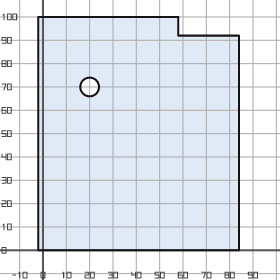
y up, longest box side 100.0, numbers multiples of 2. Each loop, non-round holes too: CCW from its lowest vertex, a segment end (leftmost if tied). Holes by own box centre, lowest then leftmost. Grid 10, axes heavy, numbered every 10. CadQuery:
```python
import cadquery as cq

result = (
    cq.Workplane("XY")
    .moveTo(-2.0, 0.0)
    .lineTo(84.0, 0.0)
    .lineTo(84.0, 92.0)
    .lineTo(58.0, 92.0)
    .lineTo(58.0, 100.0)
    .lineTo(-2.0, 100.0)
    .close()
    .moveTo(20.0, 70.0)
    .circle(4.0)
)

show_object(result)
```